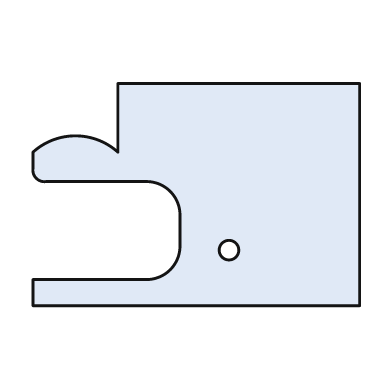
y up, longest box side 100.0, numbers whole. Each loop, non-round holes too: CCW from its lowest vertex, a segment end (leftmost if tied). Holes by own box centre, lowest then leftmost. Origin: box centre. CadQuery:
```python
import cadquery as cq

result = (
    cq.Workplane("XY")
    .moveTo(-50.0, -34.0)
    .lineTo(50.0, -34.0)
    .lineTo(50.0, 34.0)
    .lineTo(-24.0, 34.0)
    .lineTo(-24.0, 13.0)
    .threePointArc((-37.0, 18.0), (-50.0, 13.0))
    .lineTo(-50.0, 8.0)
    .threePointArc((-49.0, 5.0), (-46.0, 4.0))
    .lineTo(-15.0, 4.0)
    .threePointArc((-8.0, 1.0), (-5.0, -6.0))
    .lineTo(-5.0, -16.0)
    .threePointArc((-8.0, -23.0), (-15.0, -26.0))
    .lineTo(-50.0, -26.0)
    .close()
    .moveTo(10.0, -17.0)
    .circle(3.0)
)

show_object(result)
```